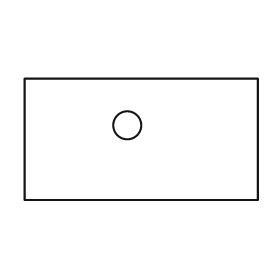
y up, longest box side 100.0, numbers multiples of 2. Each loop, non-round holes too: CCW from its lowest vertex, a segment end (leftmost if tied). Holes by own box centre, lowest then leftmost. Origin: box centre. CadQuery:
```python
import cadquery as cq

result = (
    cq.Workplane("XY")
    .moveTo(-50.0, -26.0)
    .lineTo(50.0, -26.0)
    .lineTo(50.0, 26.0)
    .lineTo(-50.0, 26.0)
    .close()
    .moveTo(-6.0, 6.0)
    .circle(6.0)
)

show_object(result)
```